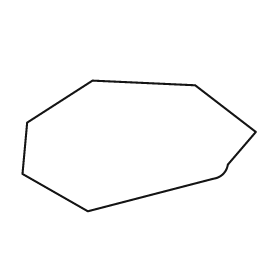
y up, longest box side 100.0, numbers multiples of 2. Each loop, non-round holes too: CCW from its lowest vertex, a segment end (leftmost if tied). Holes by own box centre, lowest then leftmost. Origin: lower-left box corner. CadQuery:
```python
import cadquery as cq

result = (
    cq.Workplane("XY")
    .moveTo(28.0, 0.0)
    .lineTo(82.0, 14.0)
    .threePointArc((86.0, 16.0), (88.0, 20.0))
    .lineTo(100.0, 34.0)
    .lineTo(74.0, 54.0)
    .lineTo(30.0, 56.0)
    .lineTo(2.0, 38.0)
    .lineTo(0.0, 16.0)
    .close()
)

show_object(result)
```